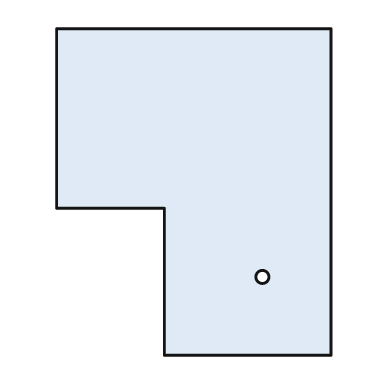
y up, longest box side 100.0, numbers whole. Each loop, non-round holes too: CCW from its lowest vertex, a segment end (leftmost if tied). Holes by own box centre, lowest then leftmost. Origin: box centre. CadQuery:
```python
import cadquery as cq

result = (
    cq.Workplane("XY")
    .moveTo(-9.0, -50.0)
    .lineTo(42.0, -50.0)
    .lineTo(42.0, 50.0)
    .lineTo(-42.0, 50.0)
    .lineTo(-42.0, -5.0)
    .lineTo(-9.0, -5.0)
    .close()
    .moveTo(21.0, -26.0)
    .circle(2.0)
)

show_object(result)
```